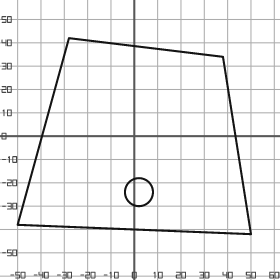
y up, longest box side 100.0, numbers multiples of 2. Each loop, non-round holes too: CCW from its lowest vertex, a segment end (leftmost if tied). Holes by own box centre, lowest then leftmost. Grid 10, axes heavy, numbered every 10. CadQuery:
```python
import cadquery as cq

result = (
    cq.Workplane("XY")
    .moveTo(50.0, -42.0)
    .lineTo(38.0, 34.0)
    .lineTo(-28.0, 42.0)
    .lineTo(-50.0, -38.0)
    .close()
    .moveTo(2.0, -24.0)
    .circle(6.0)
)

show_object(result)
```